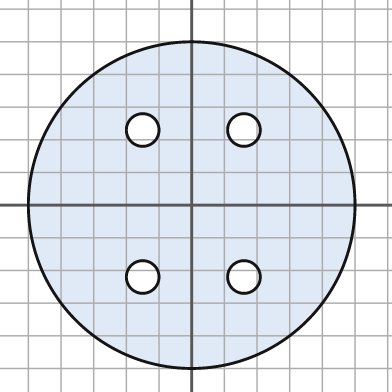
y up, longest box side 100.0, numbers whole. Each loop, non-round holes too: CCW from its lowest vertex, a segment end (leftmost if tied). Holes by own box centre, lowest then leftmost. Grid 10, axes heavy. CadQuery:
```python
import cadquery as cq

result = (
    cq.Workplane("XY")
    .moveTo(0.0, 0.0)
    .circle(50.0)
    .moveTo(-15.0, -22.0)
    .circle(5.0)
    .moveTo(16.0, -22.0)
    .circle(5.0)
    .moveTo(-15.0, 23.0)
    .circle(5.0)
    .moveTo(16.0, 23.0)
    .circle(5.0)
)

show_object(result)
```